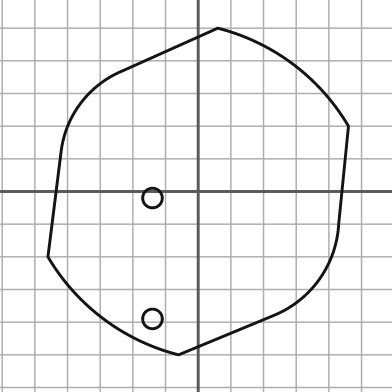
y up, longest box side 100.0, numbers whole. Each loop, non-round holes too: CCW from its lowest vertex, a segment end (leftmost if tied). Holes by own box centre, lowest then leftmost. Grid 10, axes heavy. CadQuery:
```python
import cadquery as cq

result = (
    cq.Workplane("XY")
    .moveTo(-6.0, -50.0)
    .lineTo(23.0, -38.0)
    .threePointArc((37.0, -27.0), (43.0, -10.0))
    .lineTo(46.0, 20.0)
    .threePointArc((29.0, 39.0), (6.0, 50.0))
    .lineTo(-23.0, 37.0)
    .threePointArc((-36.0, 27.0), (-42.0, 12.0))
    .lineTo(-46.0, -20.0)
    .threePointArc((-29.0, -39.0), (-6.0, -50.0))
    .close()
    .moveTo(-14.0, -39.0)
    .circle(3.0)
    .moveTo(-14.0, -2.0)
    .circle(3.0)
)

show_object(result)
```